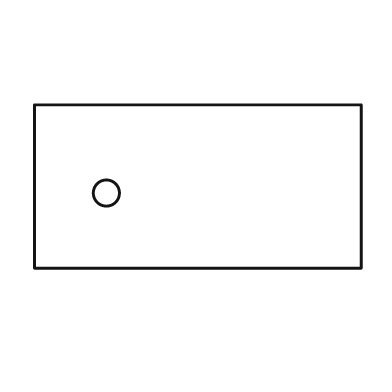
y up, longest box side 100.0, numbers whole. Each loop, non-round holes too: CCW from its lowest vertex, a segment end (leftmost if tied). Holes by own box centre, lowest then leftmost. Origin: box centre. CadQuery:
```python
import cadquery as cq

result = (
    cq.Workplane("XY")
    .moveTo(-50.0, -25.0)
    .lineTo(50.0, -25.0)
    .lineTo(50.0, 25.0)
    .lineTo(-50.0, 25.0)
    .close()
    .moveTo(-28.0, -2.0)
    .circle(4.0)
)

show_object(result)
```